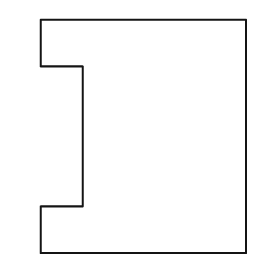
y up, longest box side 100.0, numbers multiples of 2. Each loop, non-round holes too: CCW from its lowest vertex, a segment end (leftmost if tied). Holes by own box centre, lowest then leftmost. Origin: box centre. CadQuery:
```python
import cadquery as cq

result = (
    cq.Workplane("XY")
    .moveTo(-44.0, -50.0)
    .lineTo(44.0, -50.0)
    .lineTo(44.0, 50.0)
    .lineTo(-44.0, 50.0)
    .lineTo(-44.0, 30.0)
    .lineTo(-26.0, 30.0)
    .lineTo(-26.0, -30.0)
    .lineTo(-44.0, -30.0)
    .close()
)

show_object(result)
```